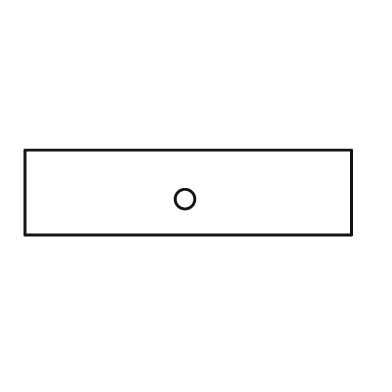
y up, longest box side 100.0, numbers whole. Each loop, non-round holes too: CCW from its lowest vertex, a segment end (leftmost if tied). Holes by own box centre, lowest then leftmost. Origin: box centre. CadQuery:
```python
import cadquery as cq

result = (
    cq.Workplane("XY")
    .moveTo(-50.0, -13.0)
    .lineTo(50.0, -13.0)
    .lineTo(50.0, 13.0)
    .lineTo(-50.0, 13.0)
    .close()
    .moveTo(-1.0, -2.0)
    .circle(3.0)
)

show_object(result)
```